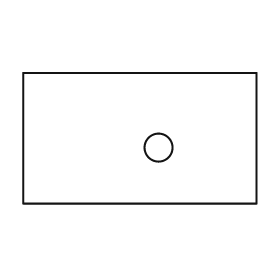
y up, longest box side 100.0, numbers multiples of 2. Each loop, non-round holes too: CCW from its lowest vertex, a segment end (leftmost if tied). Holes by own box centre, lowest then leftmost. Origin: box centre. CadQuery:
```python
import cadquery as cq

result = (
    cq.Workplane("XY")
    .moveTo(-50.0, -28.0)
    .lineTo(50.0, -28.0)
    .lineTo(50.0, 28.0)
    .lineTo(-50.0, 28.0)
    .close()
    .moveTo(8.0, -4.0)
    .circle(6.0)
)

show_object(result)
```